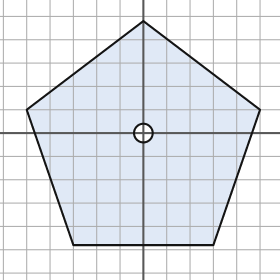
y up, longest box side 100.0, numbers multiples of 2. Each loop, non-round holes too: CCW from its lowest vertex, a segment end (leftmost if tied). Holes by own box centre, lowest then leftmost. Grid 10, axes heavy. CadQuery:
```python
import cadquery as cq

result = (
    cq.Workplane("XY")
    .moveTo(-30.0, -48.0)
    .lineTo(30.0, -48.0)
    .lineTo(50.0, 10.0)
    .lineTo(0.0, 48.0)
    .lineTo(-50.0, 10.0)
    .close()
    .moveTo(0.0, 0.0)
    .circle(4.0)
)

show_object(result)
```